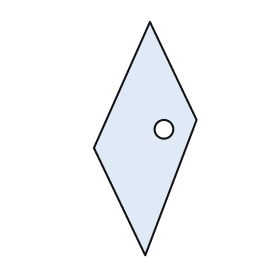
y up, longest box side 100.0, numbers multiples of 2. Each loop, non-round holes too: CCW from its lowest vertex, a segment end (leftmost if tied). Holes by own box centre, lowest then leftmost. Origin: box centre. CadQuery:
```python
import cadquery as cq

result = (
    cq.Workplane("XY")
    .moveTo(0.0, -50.0)
    .lineTo(22.0, 8.0)
    .lineTo(2.0, 50.0)
    .lineTo(-22.0, -4.0)
    .close()
    .moveTo(8.0, 4.0)
    .circle(4.0)
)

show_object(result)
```